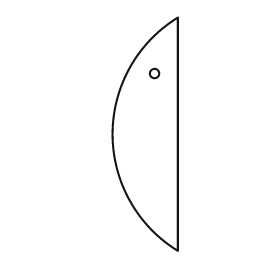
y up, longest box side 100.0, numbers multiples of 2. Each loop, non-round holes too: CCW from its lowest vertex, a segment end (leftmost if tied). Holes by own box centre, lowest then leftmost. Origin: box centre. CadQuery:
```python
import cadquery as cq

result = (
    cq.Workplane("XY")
    .moveTo(14.0, -50.0)
    .lineTo(14.0, 50.0)
    .threePointArc((-14.0, 0.0), (14.0, -50.0))
    .close()
    .moveTo(4.0, 26.0)
    .circle(2.0)
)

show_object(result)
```